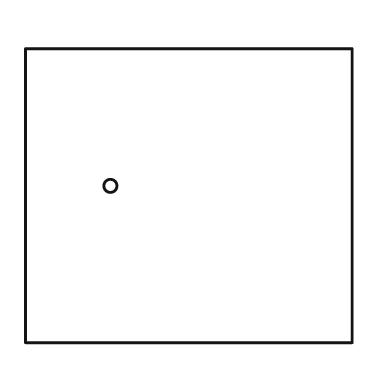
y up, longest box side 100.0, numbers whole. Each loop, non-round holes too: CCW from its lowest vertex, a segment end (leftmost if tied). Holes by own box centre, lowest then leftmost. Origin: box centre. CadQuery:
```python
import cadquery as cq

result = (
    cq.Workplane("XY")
    .moveTo(-50.0, -45.0)
    .lineTo(50.0, -45.0)
    .lineTo(50.0, 45.0)
    .lineTo(-50.0, 45.0)
    .close()
    .moveTo(-24.0, 3.0)
    .circle(2.0)
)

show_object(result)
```